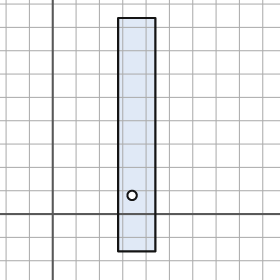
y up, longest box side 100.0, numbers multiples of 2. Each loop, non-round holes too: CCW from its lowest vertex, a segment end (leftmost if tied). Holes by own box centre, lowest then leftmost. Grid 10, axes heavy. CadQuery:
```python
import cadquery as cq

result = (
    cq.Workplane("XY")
    .moveTo(28.0, -16.0)
    .lineTo(44.0, -16.0)
    .lineTo(44.0, 84.0)
    .lineTo(28.0, 84.0)
    .close()
    .moveTo(34.0, 8.0)
    .circle(2.0)
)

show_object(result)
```